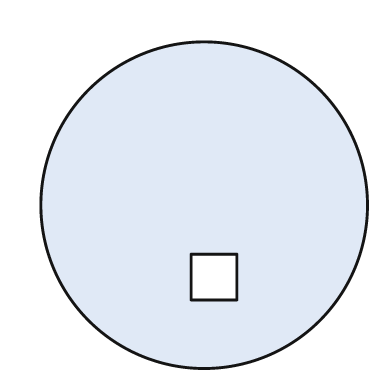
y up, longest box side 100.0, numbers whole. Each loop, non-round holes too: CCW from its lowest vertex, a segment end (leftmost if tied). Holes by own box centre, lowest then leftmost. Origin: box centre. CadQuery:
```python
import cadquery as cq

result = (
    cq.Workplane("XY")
    .moveTo(0.0, 0.0)
    .circle(50.0)
    .moveTo(-4.0, -29.0)
    .lineTo(10.0, -29.0)
    .lineTo(10.0, -15.0)
    .lineTo(-4.0, -15.0)
    .close()
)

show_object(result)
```